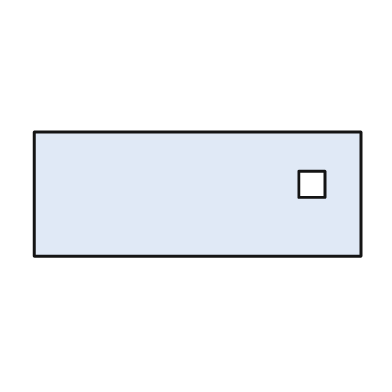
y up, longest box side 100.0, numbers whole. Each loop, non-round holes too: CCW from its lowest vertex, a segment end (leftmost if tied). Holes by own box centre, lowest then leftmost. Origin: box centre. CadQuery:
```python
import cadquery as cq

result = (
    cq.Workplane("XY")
    .moveTo(-50.0, -19.0)
    .lineTo(50.0, -19.0)
    .lineTo(50.0, 19.0)
    .lineTo(-50.0, 19.0)
    .close()
    .moveTo(31.0, -1.0)
    .lineTo(39.0, -1.0)
    .lineTo(39.0, 7.0)
    .lineTo(31.0, 7.0)
    .close()
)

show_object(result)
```